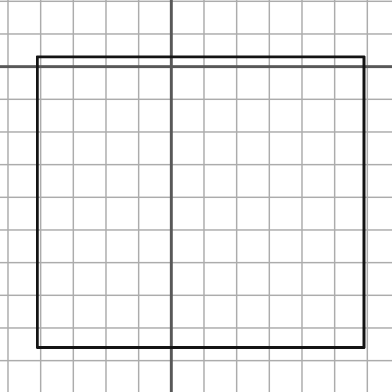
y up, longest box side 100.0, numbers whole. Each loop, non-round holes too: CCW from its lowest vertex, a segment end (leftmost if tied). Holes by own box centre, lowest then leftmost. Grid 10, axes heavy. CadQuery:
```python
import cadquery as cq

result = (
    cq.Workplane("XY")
    .moveTo(-41.0, -86.0)
    .lineTo(59.0, -86.0)
    .lineTo(59.0, 3.0)
    .lineTo(-41.0, 3.0)
    .close()
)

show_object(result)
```